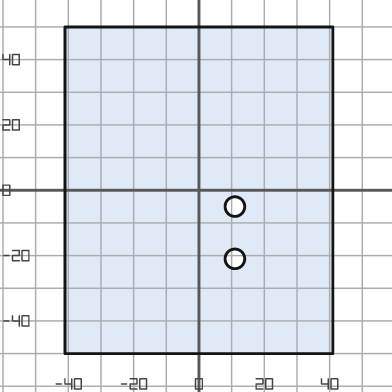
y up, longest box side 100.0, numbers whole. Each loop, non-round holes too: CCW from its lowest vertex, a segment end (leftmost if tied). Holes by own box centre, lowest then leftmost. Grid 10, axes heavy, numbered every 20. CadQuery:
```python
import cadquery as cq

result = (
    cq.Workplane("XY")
    .moveTo(-41.0, -50.0)
    .lineTo(41.0, -50.0)
    .lineTo(41.0, 50.0)
    .lineTo(-41.0, 50.0)
    .close()
    .moveTo(11.0, -21.0)
    .circle(3.0)
    .moveTo(11.0, -5.0)
    .circle(3.0)
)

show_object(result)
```